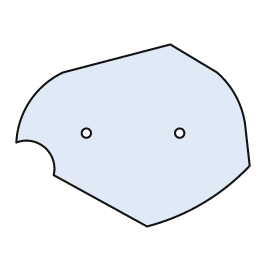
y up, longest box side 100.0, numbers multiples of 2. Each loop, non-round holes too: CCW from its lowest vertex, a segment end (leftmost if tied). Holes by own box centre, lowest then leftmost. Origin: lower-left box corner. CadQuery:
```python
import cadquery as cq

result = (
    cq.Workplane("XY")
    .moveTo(56.0, 0.0)
    .threePointArc((80.0, 10.0), (100.0, 26.0))
    .lineTo(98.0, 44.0)
    .threePointArc((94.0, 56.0), (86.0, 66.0))
    .lineTo(66.0, 78.0)
    .lineTo(20.0, 66.0)
    .threePointArc((6.0, 54.0), (0.0, 36.0))
    .threePointArc((12.0, 34.0), (16.0, 22.0))
    .close()
    .moveTo(30.0, 40.0)
    .circle(2.0)
    .moveTo(70.0, 40.0)
    .circle(2.0)
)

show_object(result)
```